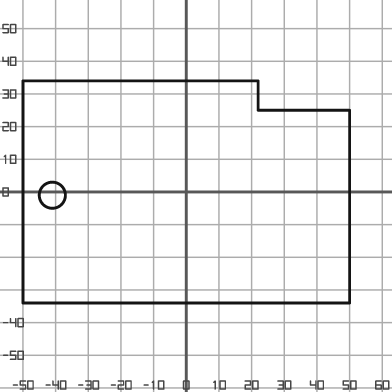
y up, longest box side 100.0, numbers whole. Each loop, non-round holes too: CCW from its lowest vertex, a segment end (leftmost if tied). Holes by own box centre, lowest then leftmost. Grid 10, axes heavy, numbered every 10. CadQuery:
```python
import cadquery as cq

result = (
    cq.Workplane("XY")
    .moveTo(-50.0, -34.0)
    .lineTo(50.0, -34.0)
    .lineTo(50.0, 25.0)
    .lineTo(22.0, 25.0)
    .lineTo(22.0, 34.0)
    .lineTo(-50.0, 34.0)
    .close()
    .moveTo(-41.0, -1.0)
    .circle(4.0)
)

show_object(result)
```